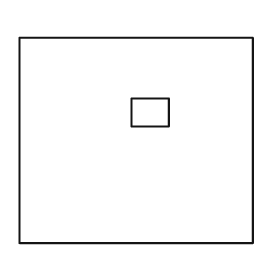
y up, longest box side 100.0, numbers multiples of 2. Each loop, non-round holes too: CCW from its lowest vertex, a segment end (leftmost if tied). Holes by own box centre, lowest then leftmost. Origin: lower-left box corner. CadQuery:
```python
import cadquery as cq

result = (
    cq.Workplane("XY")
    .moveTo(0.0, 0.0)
    .lineTo(100.0, 0.0)
    .lineTo(100.0, 88.0)
    .lineTo(0.0, 88.0)
    .close()
    .moveTo(48.0, 50.0)
    .lineTo(64.0, 50.0)
    .lineTo(64.0, 62.0)
    .lineTo(48.0, 62.0)
    .close()
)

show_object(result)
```